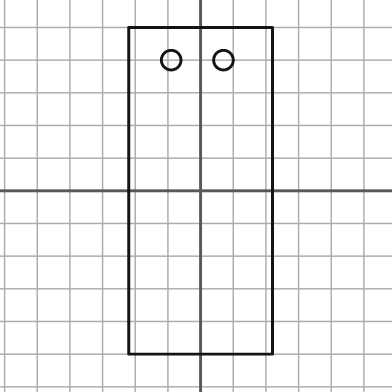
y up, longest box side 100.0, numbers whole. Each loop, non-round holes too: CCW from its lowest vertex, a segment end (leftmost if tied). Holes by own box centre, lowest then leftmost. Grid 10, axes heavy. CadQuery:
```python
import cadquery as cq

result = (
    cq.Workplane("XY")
    .moveTo(-22.0, -50.0)
    .lineTo(22.0, -50.0)
    .lineTo(22.0, 50.0)
    .lineTo(-22.0, 50.0)
    .close()
    .moveTo(-9.0, 40.0)
    .circle(3.0)
    .moveTo(7.0, 40.0)
    .circle(3.0)
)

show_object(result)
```